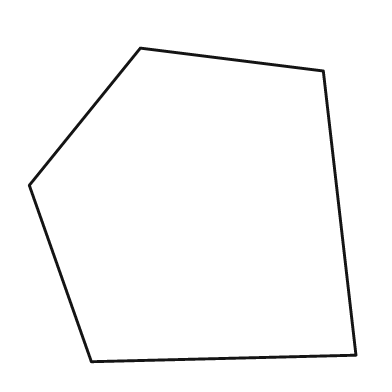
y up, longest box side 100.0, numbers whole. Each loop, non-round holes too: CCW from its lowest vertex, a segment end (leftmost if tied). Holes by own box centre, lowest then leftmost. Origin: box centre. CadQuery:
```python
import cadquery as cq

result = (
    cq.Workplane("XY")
    .moveTo(-31.0, -48.0)
    .lineTo(50.0, -46.0)
    .lineTo(40.0, 41.0)
    .lineTo(-16.0, 48.0)
    .lineTo(-50.0, 6.0)
    .close()
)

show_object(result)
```